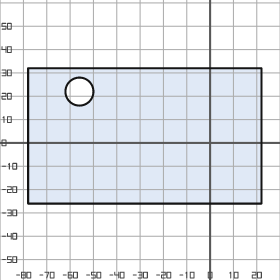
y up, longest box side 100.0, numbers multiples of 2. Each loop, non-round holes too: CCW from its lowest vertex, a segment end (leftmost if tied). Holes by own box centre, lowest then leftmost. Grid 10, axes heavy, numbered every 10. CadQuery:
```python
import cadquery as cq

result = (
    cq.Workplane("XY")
    .moveTo(-78.0, -26.0)
    .lineTo(22.0, -26.0)
    .lineTo(22.0, 32.0)
    .lineTo(-78.0, 32.0)
    .close()
    .moveTo(-56.0, 22.0)
    .circle(6.0)
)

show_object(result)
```